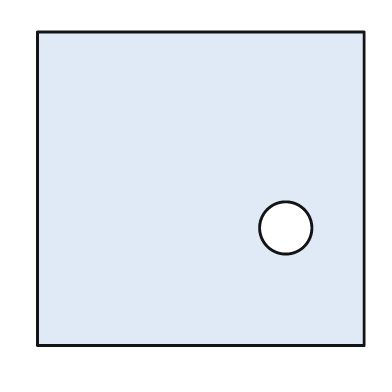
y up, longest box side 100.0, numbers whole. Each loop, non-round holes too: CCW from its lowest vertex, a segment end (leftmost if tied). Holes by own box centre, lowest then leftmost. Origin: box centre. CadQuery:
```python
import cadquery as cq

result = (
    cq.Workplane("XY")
    .moveTo(-50.0, -48.0)
    .lineTo(50.0, -48.0)
    .lineTo(50.0, 48.0)
    .lineTo(-50.0, 48.0)
    .close()
    .moveTo(26.0, -12.0)
    .circle(8.0)
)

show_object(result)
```